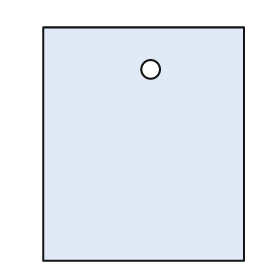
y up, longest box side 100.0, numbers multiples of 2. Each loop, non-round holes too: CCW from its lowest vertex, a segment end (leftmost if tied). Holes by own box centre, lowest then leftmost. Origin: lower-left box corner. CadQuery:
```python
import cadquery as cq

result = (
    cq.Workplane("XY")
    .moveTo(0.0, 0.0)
    .lineTo(86.0, 0.0)
    .lineTo(86.0, 100.0)
    .lineTo(0.0, 100.0)
    .close()
    .moveTo(46.0, 82.0)
    .circle(4.0)
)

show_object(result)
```